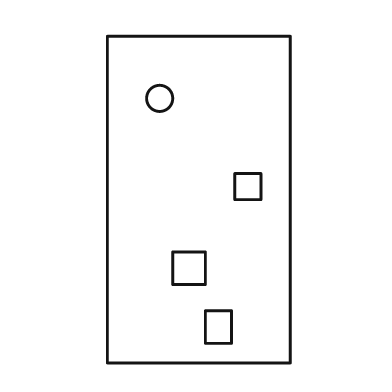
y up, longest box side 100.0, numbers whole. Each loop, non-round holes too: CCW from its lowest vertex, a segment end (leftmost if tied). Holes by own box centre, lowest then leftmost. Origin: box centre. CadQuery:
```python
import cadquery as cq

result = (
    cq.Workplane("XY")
    .moveTo(-28.0, -50.0)
    .lineTo(28.0, -50.0)
    .lineTo(28.0, 50.0)
    .lineTo(-28.0, 50.0)
    .close()
    .moveTo(2.0, -44.0)
    .lineTo(10.0, -44.0)
    .lineTo(10.0, -34.0)
    .lineTo(2.0, -34.0)
    .close()
    .moveTo(-8.0, -26.0)
    .lineTo(2.0, -26.0)
    .lineTo(2.0, -16.0)
    .lineTo(-8.0, -16.0)
    .close()
    .moveTo(11.0, 0.0)
    .lineTo(19.0, 0.0)
    .lineTo(19.0, 8.0)
    .lineTo(11.0, 8.0)
    .close()
    .moveTo(-12.0, 31.0)
    .circle(4.0)
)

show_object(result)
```